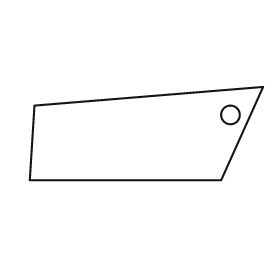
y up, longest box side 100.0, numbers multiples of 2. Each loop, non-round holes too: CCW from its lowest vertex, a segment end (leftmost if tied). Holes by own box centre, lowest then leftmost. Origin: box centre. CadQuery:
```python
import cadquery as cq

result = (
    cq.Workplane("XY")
    .moveTo(-50.0, -20.0)
    .lineTo(32.0, -20.0)
    .lineTo(50.0, 20.0)
    .lineTo(-48.0, 12.0)
    .close()
    .moveTo(36.0, 8.0)
    .circle(4.0)
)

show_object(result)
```